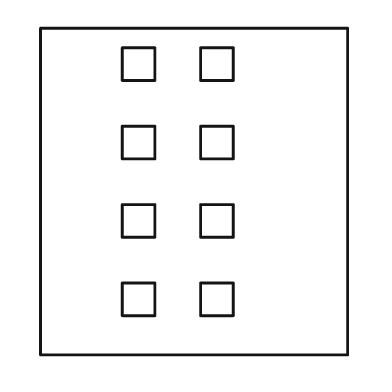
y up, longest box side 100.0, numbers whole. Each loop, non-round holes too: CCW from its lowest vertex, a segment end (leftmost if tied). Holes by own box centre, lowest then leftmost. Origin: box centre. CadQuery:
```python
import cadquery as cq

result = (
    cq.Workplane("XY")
    .moveTo(-47.0, -50.0)
    .lineTo(47.0, -50.0)
    .lineTo(47.0, 50.0)
    .lineTo(-47.0, 50.0)
    .close()
    .moveTo(-22.0, -38.0)
    .lineTo(-12.0, -38.0)
    .lineTo(-12.0, -28.0)
    .lineTo(-22.0, -28.0)
    .close()
    .moveTo(2.0, -38.0)
    .lineTo(12.0, -38.0)
    .lineTo(12.0, -28.0)
    .lineTo(2.0, -28.0)
    .close()
    .moveTo(-22.0, -14.0)
    .lineTo(-12.0, -14.0)
    .lineTo(-12.0, -4.0)
    .lineTo(-22.0, -4.0)
    .close()
    .moveTo(2.0, -14.0)
    .lineTo(12.0, -14.0)
    .lineTo(12.0, -4.0)
    .lineTo(2.0, -4.0)
    .close()
    .moveTo(-22.0, 10.0)
    .lineTo(-12.0, 10.0)
    .lineTo(-12.0, 20.0)
    .lineTo(-22.0, 20.0)
    .close()
    .moveTo(2.0, 10.0)
    .lineTo(12.0, 10.0)
    .lineTo(12.0, 20.0)
    .lineTo(2.0, 20.0)
    .close()
    .moveTo(-22.0, 34.0)
    .lineTo(-12.0, 34.0)
    .lineTo(-12.0, 44.0)
    .lineTo(-22.0, 44.0)
    .close()
    .moveTo(2.0, 34.0)
    .lineTo(12.0, 34.0)
    .lineTo(12.0, 44.0)
    .lineTo(2.0, 44.0)
    .close()
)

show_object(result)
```